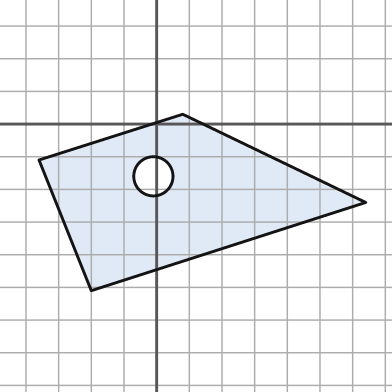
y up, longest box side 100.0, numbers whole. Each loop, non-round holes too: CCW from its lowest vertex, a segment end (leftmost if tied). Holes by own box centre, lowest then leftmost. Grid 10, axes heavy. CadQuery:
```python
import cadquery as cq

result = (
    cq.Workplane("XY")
    .moveTo(-20.0, -51.0)
    .lineTo(64.0, -24.0)
    .lineTo(8.0, 3.0)
    .lineTo(-36.0, -11.0)
    .close()
    .moveTo(-1.0, -16.0)
    .circle(6.0)
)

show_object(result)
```